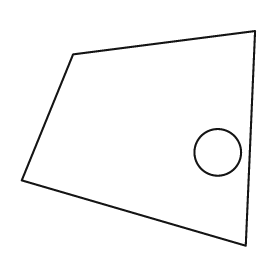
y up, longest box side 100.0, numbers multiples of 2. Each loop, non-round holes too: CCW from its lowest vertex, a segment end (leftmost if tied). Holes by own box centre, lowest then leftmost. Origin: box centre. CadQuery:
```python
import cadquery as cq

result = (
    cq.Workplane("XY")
    .moveTo(46.0, -46.0)
    .lineTo(50.0, 46.0)
    .lineTo(-28.0, 36.0)
    .lineTo(-50.0, -18.0)
    .close()
    .moveTo(34.0, -6.0)
    .circle(10.0)
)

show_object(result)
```